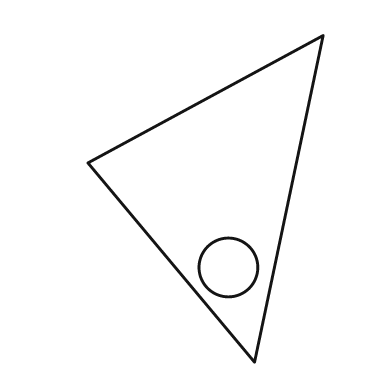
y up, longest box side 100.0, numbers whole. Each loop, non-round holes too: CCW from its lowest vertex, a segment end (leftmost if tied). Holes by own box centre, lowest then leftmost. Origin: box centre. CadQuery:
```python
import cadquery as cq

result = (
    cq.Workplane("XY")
    .moveTo(15.0, -50.0)
    .lineTo(36.0, 50.0)
    .lineTo(-36.0, 11.0)
    .close()
    .moveTo(7.0, -21.0)
    .circle(9.0)
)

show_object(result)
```